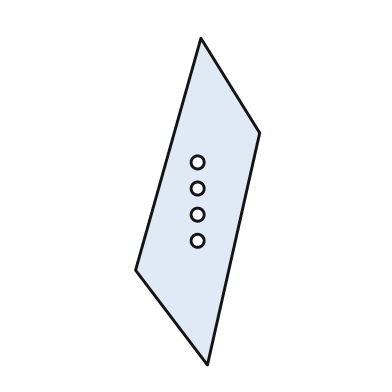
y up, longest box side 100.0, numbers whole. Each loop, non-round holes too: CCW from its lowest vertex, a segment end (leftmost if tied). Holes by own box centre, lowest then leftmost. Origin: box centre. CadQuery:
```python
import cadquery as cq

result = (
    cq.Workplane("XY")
    .moveTo(3.0, -50.0)
    .lineTo(19.0, 21.0)
    .lineTo(1.0, 50.0)
    .lineTo(-19.0, -21.0)
    .close()
    .moveTo(0.0, -12.0)
    .circle(2.0)
    .moveTo(0.0, -4.0)
    .circle(2.0)
    .moveTo(0.0, 4.0)
    .circle(2.0)
    .moveTo(0.0, 12.0)
    .circle(2.0)
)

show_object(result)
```